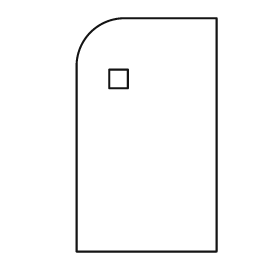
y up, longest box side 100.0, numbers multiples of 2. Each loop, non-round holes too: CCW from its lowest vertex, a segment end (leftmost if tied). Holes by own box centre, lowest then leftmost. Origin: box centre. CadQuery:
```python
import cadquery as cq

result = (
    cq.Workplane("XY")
    .moveTo(-30.0, -50.0)
    .lineTo(30.0, -50.0)
    .lineTo(30.0, 50.0)
    .lineTo(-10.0, 50.0)
    .threePointArc((-24.0, 44.0), (-30.0, 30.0))
    .close()
    .moveTo(-16.0, 20.0)
    .lineTo(-8.0, 20.0)
    .lineTo(-8.0, 28.0)
    .lineTo(-16.0, 28.0)
    .close()
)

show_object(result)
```